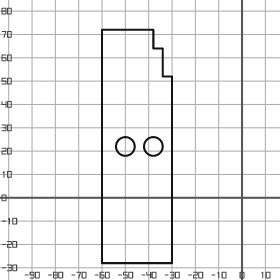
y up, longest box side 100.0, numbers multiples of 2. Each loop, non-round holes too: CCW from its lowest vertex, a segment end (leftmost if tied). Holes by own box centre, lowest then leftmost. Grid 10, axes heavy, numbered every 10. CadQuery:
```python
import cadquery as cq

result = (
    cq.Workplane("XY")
    .moveTo(-60.0, -28.0)
    .lineTo(-30.0, -28.0)
    .lineTo(-30.0, 52.0)
    .lineTo(-34.0, 52.0)
    .lineTo(-34.0, 64.0)
    .lineTo(-38.0, 64.0)
    .lineTo(-38.0, 72.0)
    .lineTo(-60.0, 72.0)
    .close()
    .moveTo(-50.0, 22.0)
    .circle(4.0)
    .moveTo(-38.0, 22.0)
    .circle(4.0)
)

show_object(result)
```